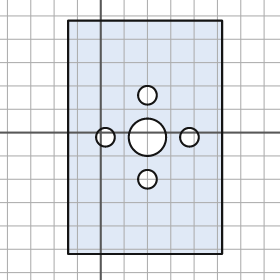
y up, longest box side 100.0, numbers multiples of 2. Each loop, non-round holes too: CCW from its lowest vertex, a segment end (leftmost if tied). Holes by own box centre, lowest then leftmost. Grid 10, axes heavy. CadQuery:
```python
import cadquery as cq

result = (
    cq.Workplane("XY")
    .moveTo(-14.0, -52.0)
    .lineTo(52.0, -52.0)
    .lineTo(52.0, 48.0)
    .lineTo(-14.0, 48.0)
    .close()
    .moveTo(20.0, -20.0)
    .circle(4.0)
    .moveTo(2.0, -2.0)
    .circle(4.0)
    .moveTo(20.0, -2.0)
    .circle(8.0)
    .moveTo(38.0, -2.0)
    .circle(4.0)
    .moveTo(20.0, 16.0)
    .circle(4.0)
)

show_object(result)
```